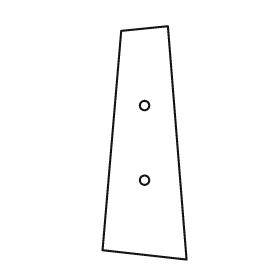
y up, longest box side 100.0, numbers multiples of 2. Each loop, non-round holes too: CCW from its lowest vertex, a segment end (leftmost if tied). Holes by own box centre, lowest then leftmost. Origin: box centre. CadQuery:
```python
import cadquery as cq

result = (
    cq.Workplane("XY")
    .moveTo(18.0, -50.0)
    .lineTo(10.0, 50.0)
    .lineTo(-10.0, 48.0)
    .lineTo(-18.0, -46.0)
    .close()
    .moveTo(0.0, -16.0)
    .circle(2.0)
    .moveTo(0.0, 16.0)
    .circle(2.0)
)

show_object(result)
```